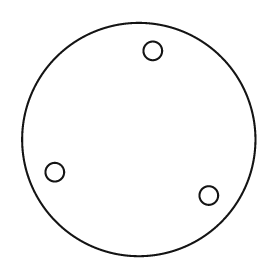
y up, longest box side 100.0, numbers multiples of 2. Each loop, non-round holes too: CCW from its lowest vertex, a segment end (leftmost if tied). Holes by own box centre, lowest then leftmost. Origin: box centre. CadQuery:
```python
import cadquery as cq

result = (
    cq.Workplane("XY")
    .moveTo(0.0, 0.0)
    .circle(50.0)
    .moveTo(30.0, -24.0)
    .circle(4.0)
    .moveTo(-36.0, -14.0)
    .circle(4.0)
    .moveTo(6.0, 38.0)
    .circle(4.0)
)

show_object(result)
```